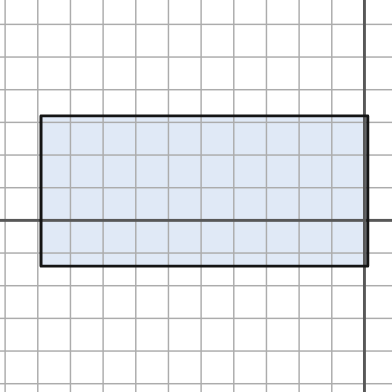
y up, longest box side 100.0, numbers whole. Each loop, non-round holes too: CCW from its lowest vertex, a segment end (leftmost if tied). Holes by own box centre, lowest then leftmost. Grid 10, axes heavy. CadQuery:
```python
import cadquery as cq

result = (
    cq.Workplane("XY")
    .moveTo(-99.0, -14.0)
    .lineTo(1.0, -14.0)
    .lineTo(1.0, 32.0)
    .lineTo(-99.0, 32.0)
    .close()
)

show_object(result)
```